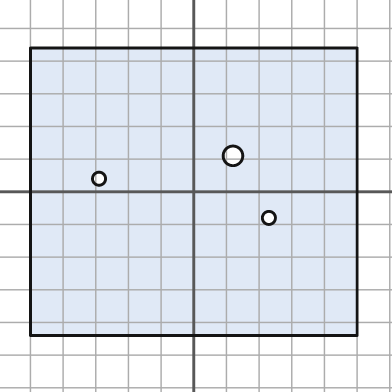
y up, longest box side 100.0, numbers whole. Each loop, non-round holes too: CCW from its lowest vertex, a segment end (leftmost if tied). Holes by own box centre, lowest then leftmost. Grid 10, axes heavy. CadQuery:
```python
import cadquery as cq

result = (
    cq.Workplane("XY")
    .moveTo(-50.0, -44.0)
    .lineTo(50.0, -44.0)
    .lineTo(50.0, 44.0)
    .lineTo(-50.0, 44.0)
    .close()
    .moveTo(23.0, -8.0)
    .circle(2.0)
    .moveTo(-29.0, 4.0)
    .circle(2.0)
    .moveTo(12.0, 11.0)
    .circle(3.0)
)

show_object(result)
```